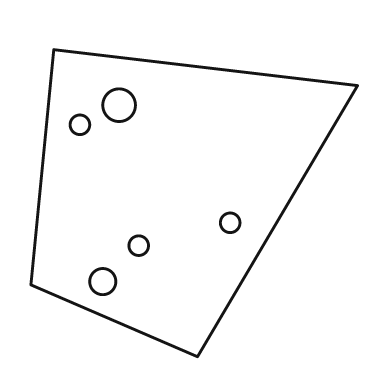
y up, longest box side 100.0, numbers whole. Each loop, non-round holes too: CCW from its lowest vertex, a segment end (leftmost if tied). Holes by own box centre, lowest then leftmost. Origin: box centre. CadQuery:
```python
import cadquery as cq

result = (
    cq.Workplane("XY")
    .moveTo(1.0, -47.0)
    .lineTo(50.0, 36.0)
    .lineTo(-43.0, 47.0)
    .lineTo(-50.0, -25.0)
    .close()
    .moveTo(-28.0, -24.0)
    .circle(4.0)
    .moveTo(-17.0, -13.0)
    .circle(3.0)
    .moveTo(11.0, -6.0)
    .circle(3.0)
    .moveTo(-35.0, 24.0)
    .circle(3.0)
    .moveTo(-23.0, 30.0)
    .circle(5.0)
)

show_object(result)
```